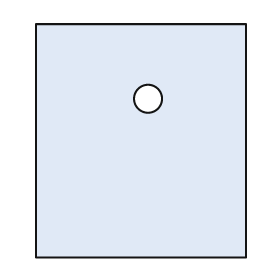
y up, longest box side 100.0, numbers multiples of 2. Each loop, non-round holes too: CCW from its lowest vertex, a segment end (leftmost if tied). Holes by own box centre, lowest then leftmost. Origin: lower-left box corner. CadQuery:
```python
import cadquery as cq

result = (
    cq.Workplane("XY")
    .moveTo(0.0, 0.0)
    .lineTo(90.0, 0.0)
    .lineTo(90.0, 100.0)
    .lineTo(0.0, 100.0)
    .close()
    .moveTo(48.0, 68.0)
    .circle(6.0)
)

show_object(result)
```